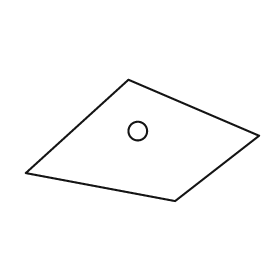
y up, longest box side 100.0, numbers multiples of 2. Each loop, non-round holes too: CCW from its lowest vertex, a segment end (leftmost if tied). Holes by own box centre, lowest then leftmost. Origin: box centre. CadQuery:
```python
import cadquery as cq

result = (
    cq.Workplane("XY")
    .moveTo(14.0, -26.0)
    .lineTo(50.0, 2.0)
    .lineTo(-6.0, 26.0)
    .lineTo(-50.0, -14.0)
    .close()
    .moveTo(-2.0, 4.0)
    .circle(4.0)
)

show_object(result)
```